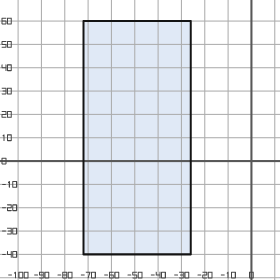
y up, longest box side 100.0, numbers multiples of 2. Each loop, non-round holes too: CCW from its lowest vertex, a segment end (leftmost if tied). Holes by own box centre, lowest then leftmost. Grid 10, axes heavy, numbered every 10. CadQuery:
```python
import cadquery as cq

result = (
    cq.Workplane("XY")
    .moveTo(-72.0, -40.0)
    .lineTo(-26.0, -40.0)
    .lineTo(-26.0, 60.0)
    .lineTo(-72.0, 60.0)
    .close()
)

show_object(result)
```